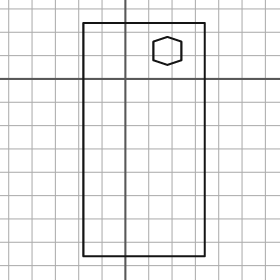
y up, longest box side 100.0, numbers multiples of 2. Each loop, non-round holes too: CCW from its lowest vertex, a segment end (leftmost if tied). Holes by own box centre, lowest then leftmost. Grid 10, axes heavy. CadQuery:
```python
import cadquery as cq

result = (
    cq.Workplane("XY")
    .moveTo(-18.0, -76.0)
    .lineTo(34.0, -76.0)
    .lineTo(34.0, 24.0)
    .lineTo(-18.0, 24.0)
    .close()
    .moveTo(18.0, 6.0)
    .lineTo(24.0, 8.0)
    .lineTo(24.0, 16.0)
    .lineTo(18.0, 18.0)
    .lineTo(12.0, 16.0)
    .lineTo(12.0, 8.0)
    .close()
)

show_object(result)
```